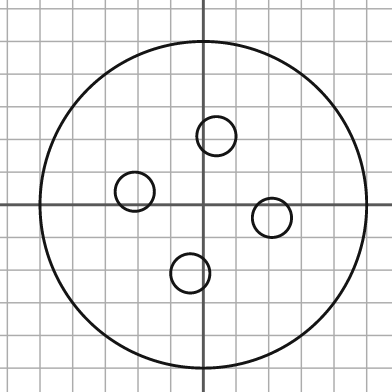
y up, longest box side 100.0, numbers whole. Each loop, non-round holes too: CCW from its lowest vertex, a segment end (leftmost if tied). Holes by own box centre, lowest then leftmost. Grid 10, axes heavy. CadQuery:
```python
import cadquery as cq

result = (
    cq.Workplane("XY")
    .moveTo(0.0, 0.0)
    .circle(50.0)
    .moveTo(-4.0, -21.0)
    .circle(6.0)
    .moveTo(21.0, -4.0)
    .circle(6.0)
    .moveTo(-21.0, 4.0)
    .circle(6.0)
    .moveTo(4.0, 21.0)
    .circle(6.0)
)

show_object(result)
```